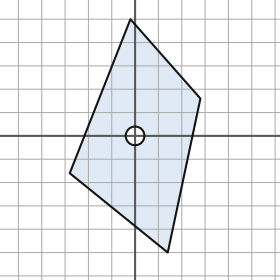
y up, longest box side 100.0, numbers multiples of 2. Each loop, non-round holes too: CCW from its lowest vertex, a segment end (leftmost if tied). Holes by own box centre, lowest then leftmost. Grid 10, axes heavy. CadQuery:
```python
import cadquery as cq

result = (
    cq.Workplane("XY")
    .moveTo(14.0, -50.0)
    .lineTo(28.0, 16.0)
    .lineTo(-2.0, 50.0)
    .lineTo(-28.0, -16.0)
    .close()
    .moveTo(0.0, 0.0)
    .circle(4.0)
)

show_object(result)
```